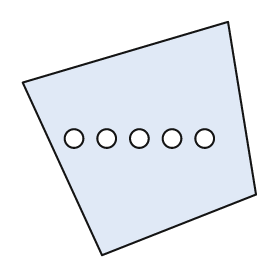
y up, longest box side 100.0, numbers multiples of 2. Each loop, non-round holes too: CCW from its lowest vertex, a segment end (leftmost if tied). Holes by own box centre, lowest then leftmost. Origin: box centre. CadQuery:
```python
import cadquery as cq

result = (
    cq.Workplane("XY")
    .moveTo(-16.0, -50.0)
    .lineTo(50.0, -24.0)
    .lineTo(38.0, 50.0)
    .lineTo(-50.0, 24.0)
    .close()
    .moveTo(-28.0, 0.0)
    .circle(4.0)
    .moveTo(-14.0, 0.0)
    .circle(4.0)
    .moveTo(0.0, 0.0)
    .circle(4.0)
    .moveTo(14.0, 0.0)
    .circle(4.0)
    .moveTo(28.0, 0.0)
    .circle(4.0)
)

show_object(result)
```